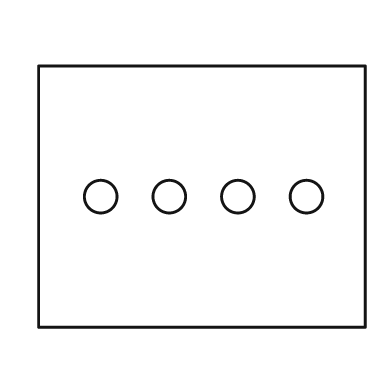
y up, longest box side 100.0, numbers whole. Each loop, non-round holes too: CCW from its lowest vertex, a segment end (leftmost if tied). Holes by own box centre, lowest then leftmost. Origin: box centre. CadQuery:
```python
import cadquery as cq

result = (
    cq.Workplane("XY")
    .moveTo(-50.0, -40.0)
    .lineTo(50.0, -40.0)
    .lineTo(50.0, 40.0)
    .lineTo(-50.0, 40.0)
    .close()
    .moveTo(-31.0, 0.0)
    .circle(5.0)
    .moveTo(-10.0, 0.0)
    .circle(5.0)
    .moveTo(11.0, 0.0)
    .circle(5.0)
    .moveTo(32.0, 0.0)
    .circle(5.0)
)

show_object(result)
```